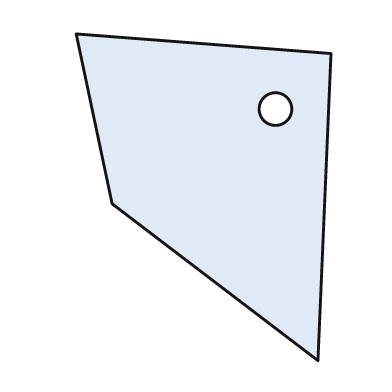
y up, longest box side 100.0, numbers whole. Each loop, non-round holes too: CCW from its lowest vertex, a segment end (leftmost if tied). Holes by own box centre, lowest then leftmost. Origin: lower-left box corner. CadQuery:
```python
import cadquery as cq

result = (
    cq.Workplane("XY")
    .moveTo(74.0, 0.0)
    .lineTo(78.0, 94.0)
    .lineTo(0.0, 100.0)
    .lineTo(11.0, 48.0)
    .close()
    .moveTo(61.0, 77.0)
    .circle(5.0)
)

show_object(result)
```